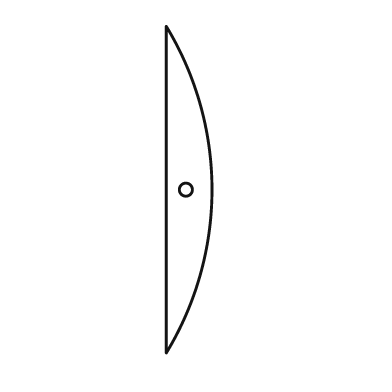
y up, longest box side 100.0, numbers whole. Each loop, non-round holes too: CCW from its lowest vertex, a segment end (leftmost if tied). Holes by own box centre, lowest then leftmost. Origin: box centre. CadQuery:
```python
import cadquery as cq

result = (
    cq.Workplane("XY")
    .moveTo(-7.0, -50.0)
    .threePointArc((7.0, 0.0), (-7.0, 50.0))
    .close()
    .moveTo(-1.0, 0.0)
    .circle(2.0)
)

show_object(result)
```